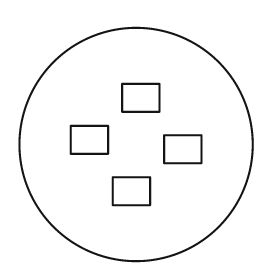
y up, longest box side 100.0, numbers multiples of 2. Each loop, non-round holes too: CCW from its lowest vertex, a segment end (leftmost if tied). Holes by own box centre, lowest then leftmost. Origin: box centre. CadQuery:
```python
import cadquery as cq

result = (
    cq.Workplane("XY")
    .moveTo(0.0, 0.0)
    .circle(50.0)
    .moveTo(-10.0, -26.0)
    .lineTo(6.0, -26.0)
    .lineTo(6.0, -14.0)
    .lineTo(-10.0, -14.0)
    .close()
    .moveTo(12.0, -8.0)
    .lineTo(28.0, -8.0)
    .lineTo(28.0, 4.0)
    .lineTo(12.0, 4.0)
    .close()
    .moveTo(-28.0, -4.0)
    .lineTo(-12.0, -4.0)
    .lineTo(-12.0, 8.0)
    .lineTo(-28.0, 8.0)
    .close()
    .moveTo(-6.0, 14.0)
    .lineTo(10.0, 14.0)
    .lineTo(10.0, 26.0)
    .lineTo(-6.0, 26.0)
    .close()
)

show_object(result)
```